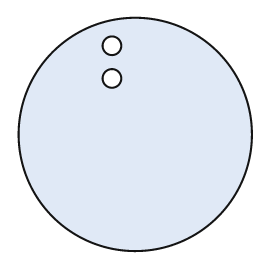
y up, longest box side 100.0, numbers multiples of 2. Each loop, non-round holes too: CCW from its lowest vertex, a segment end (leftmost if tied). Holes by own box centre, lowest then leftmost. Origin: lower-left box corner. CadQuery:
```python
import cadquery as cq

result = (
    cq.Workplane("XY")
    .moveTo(50.0, 50.0)
    .circle(50.0)
    .moveTo(40.0, 74.0)
    .circle(4.0)
    .moveTo(40.0, 88.0)
    .circle(4.0)
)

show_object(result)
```